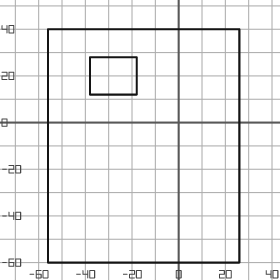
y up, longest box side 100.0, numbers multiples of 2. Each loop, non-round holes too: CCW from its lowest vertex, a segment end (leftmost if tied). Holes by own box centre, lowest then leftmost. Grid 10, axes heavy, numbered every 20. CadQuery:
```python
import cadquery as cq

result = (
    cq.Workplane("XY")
    .moveTo(-56.0, -60.0)
    .lineTo(26.0, -60.0)
    .lineTo(26.0, 40.0)
    .lineTo(-56.0, 40.0)
    .close()
    .moveTo(-38.0, 12.0)
    .lineTo(-18.0, 12.0)
    .lineTo(-18.0, 28.0)
    .lineTo(-38.0, 28.0)
    .close()
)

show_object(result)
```